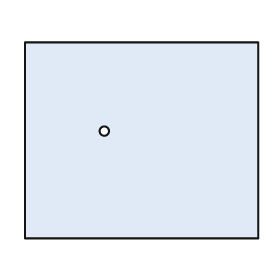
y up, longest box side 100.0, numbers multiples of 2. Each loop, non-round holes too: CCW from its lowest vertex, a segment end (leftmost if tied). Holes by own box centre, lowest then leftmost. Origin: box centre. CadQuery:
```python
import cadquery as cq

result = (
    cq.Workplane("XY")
    .moveTo(-50.0, -42.0)
    .lineTo(50.0, -42.0)
    .lineTo(50.0, 42.0)
    .lineTo(-50.0, 42.0)
    .close()
    .moveTo(-16.0, 4.0)
    .circle(2.0)
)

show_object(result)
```